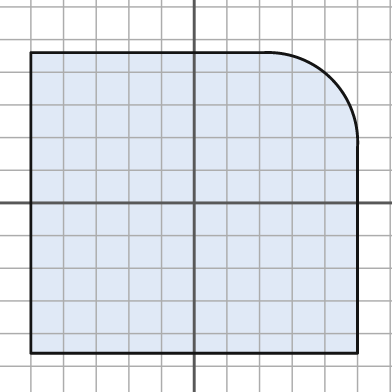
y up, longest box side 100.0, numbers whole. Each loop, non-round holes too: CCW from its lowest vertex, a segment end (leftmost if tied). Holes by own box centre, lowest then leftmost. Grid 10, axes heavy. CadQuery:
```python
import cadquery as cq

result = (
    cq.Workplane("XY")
    .moveTo(-50.0, -46.0)
    .lineTo(50.0, -46.0)
    .lineTo(50.0, 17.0)
    .threePointArc((42.0, 38.0), (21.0, 46.0))
    .lineTo(-50.0, 46.0)
    .close()
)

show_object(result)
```